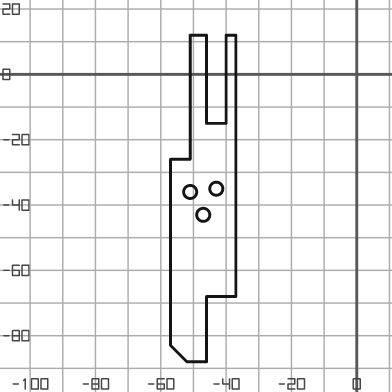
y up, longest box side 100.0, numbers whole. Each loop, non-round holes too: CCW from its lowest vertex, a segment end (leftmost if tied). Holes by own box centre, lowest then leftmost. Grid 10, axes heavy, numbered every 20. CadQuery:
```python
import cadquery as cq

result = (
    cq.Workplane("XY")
    .moveTo(-52.0, -88.0)
    .lineTo(-46.0, -88.0)
    .lineTo(-46.0, -68.0)
    .lineTo(-37.0, -68.0)
    .lineTo(-37.0, 12.0)
    .lineTo(-40.0, 12.0)
    .lineTo(-40.0, -15.0)
    .lineTo(-46.0, -15.0)
    .lineTo(-46.0, 12.0)
    .lineTo(-51.0, 12.0)
    .lineTo(-51.0, -26.0)
    .lineTo(-57.0, -26.0)
    .lineTo(-57.0, -83.0)
    .close()
    .moveTo(-47.0, -43.0)
    .circle(2.0)
    .moveTo(-51.0, -36.0)
    .circle(2.0)
    .moveTo(-43.0, -35.0)
    .circle(2.0)
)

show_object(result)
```